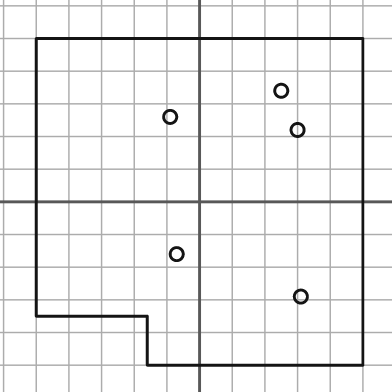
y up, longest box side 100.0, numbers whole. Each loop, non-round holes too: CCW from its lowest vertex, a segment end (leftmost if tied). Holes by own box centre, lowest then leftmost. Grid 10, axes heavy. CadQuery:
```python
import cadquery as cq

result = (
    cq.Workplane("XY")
    .moveTo(-16.0, -50.0)
    .lineTo(50.0, -50.0)
    .lineTo(50.0, 50.0)
    .lineTo(-50.0, 50.0)
    .lineTo(-50.0, -35.0)
    .lineTo(-16.0, -35.0)
    .close()
    .moveTo(31.0, -29.0)
    .circle(2.0)
    .moveTo(-7.0, -16.0)
    .circle(2.0)
    .moveTo(30.0, 22.0)
    .circle(2.0)
    .moveTo(-9.0, 26.0)
    .circle(2.0)
    .moveTo(25.0, 34.0)
    .circle(2.0)
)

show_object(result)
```